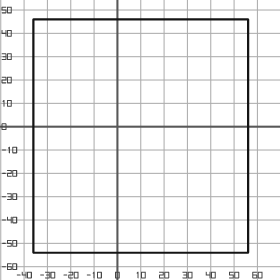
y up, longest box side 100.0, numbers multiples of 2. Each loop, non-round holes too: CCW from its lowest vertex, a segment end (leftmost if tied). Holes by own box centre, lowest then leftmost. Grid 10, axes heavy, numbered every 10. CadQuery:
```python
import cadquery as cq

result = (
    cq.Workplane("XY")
    .moveTo(-36.0, -54.0)
    .lineTo(56.0, -54.0)
    .lineTo(56.0, 46.0)
    .lineTo(-36.0, 46.0)
    .close()
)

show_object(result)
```